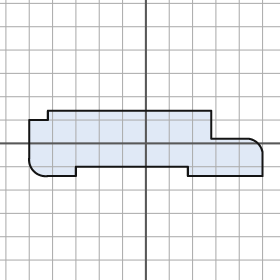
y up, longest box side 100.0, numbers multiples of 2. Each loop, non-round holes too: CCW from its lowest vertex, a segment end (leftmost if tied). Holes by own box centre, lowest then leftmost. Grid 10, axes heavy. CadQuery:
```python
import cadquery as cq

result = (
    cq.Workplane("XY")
    .moveTo(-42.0, -14.0)
    .lineTo(-30.0, -14.0)
    .lineTo(-30.0, -10.0)
    .lineTo(18.0, -10.0)
    .lineTo(18.0, -14.0)
    .lineTo(50.0, -14.0)
    .lineTo(50.0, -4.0)
    .threePointArc((48.0, 0.0), (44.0, 2.0))
    .lineTo(28.0, 2.0)
    .lineTo(28.0, 14.0)
    .lineTo(-42.0, 14.0)
    .lineTo(-42.0, 10.0)
    .lineTo(-50.0, 10.0)
    .lineTo(-50.0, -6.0)
    .threePointArc((-48.0, -12.0), (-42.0, -14.0))
    .close()
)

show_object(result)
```